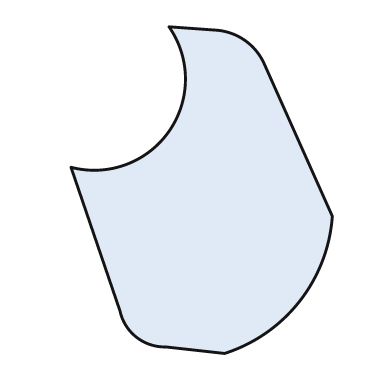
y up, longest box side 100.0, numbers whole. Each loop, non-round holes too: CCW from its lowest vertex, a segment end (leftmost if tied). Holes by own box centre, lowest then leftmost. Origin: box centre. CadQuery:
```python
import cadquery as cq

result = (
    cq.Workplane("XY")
    .moveTo(7.0, -50.0)
    .threePointArc((30.0, -34.0), (40.0, -8.0))
    .lineTo(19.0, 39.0)
    .threePointArc((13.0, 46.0), (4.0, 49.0))
    .lineTo(-10.0, 50.0)
    .threePointArc((-10.0, 18.0), (-40.0, 7.0))
    .lineTo(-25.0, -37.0)
    .threePointArc((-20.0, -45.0), (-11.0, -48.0))
    .close()
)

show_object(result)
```